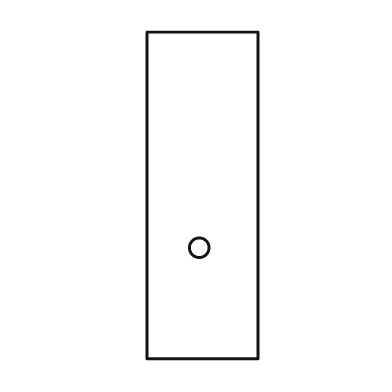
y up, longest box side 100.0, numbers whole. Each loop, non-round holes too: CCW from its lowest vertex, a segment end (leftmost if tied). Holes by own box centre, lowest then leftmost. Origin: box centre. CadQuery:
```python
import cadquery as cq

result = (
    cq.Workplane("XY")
    .moveTo(-17.0, -50.0)
    .lineTo(17.0, -50.0)
    .lineTo(17.0, 50.0)
    .lineTo(-17.0, 50.0)
    .close()
    .moveTo(-1.0, -16.0)
    .circle(3.0)
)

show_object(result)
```